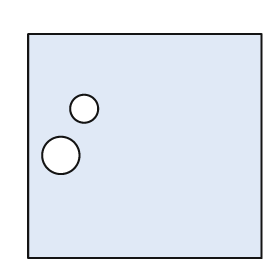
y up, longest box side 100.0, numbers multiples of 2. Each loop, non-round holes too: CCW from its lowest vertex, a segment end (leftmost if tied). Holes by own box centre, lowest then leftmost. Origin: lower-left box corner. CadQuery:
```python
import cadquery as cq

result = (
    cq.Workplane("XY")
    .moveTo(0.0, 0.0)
    .lineTo(100.0, 0.0)
    .lineTo(100.0, 96.0)
    .lineTo(0.0, 96.0)
    .close()
    .moveTo(14.0, 44.0)
    .circle(8.0)
    .moveTo(24.0, 64.0)
    .circle(6.0)
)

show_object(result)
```